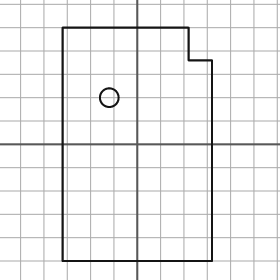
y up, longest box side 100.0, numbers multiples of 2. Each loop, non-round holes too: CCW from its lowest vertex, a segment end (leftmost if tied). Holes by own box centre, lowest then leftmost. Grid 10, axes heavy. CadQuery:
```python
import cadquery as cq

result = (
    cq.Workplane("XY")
    .moveTo(-32.0, -50.0)
    .lineTo(32.0, -50.0)
    .lineTo(32.0, 36.0)
    .lineTo(22.0, 36.0)
    .lineTo(22.0, 50.0)
    .lineTo(-32.0, 50.0)
    .close()
    .moveTo(-12.0, 20.0)
    .circle(4.0)
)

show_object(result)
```